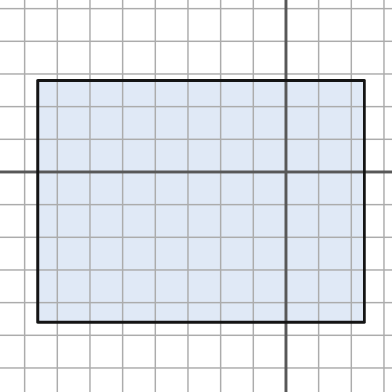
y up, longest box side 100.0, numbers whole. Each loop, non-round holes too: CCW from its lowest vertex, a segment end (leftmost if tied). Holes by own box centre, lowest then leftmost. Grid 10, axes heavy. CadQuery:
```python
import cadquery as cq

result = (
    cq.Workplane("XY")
    .moveTo(-76.0, -46.0)
    .lineTo(24.0, -46.0)
    .lineTo(24.0, 28.0)
    .lineTo(-76.0, 28.0)
    .close()
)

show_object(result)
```